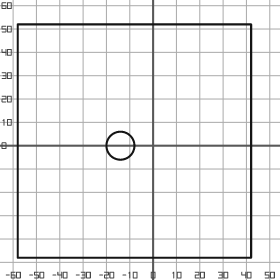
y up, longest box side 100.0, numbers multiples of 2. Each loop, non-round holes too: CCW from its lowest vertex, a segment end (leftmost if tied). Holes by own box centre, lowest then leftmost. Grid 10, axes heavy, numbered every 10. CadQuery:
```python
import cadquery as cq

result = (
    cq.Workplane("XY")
    .moveTo(-58.0, -48.0)
    .lineTo(42.0, -48.0)
    .lineTo(42.0, 52.0)
    .lineTo(-58.0, 52.0)
    .close()
    .moveTo(-14.0, 0.0)
    .circle(6.0)
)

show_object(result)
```